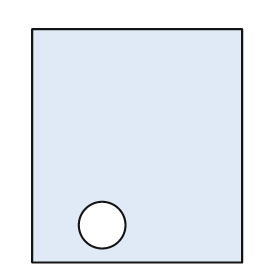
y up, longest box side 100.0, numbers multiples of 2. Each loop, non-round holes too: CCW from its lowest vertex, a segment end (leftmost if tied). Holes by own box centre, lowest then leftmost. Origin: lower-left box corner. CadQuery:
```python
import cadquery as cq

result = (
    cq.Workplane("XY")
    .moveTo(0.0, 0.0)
    .lineTo(90.0, 0.0)
    .lineTo(90.0, 100.0)
    .lineTo(0.0, 100.0)
    .close()
    .moveTo(30.0, 16.0)
    .circle(10.0)
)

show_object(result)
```